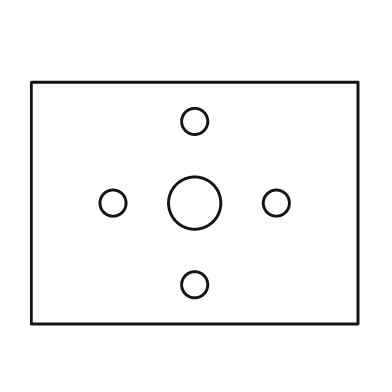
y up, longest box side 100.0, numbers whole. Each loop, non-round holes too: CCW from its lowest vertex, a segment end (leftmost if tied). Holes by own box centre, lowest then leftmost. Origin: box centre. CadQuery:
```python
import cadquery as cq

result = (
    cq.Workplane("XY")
    .moveTo(-50.0, -37.0)
    .lineTo(50.0, -37.0)
    .lineTo(50.0, 37.0)
    .lineTo(-50.0, 37.0)
    .close()
    .moveTo(0.0, -25.0)
    .circle(4.0)
    .moveTo(-25.0, 0.0)
    .circle(4.0)
    .moveTo(0.0, 0.0)
    .circle(8.0)
    .moveTo(25.0, 0.0)
    .circle(4.0)
    .moveTo(0.0, 25.0)
    .circle(4.0)
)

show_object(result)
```